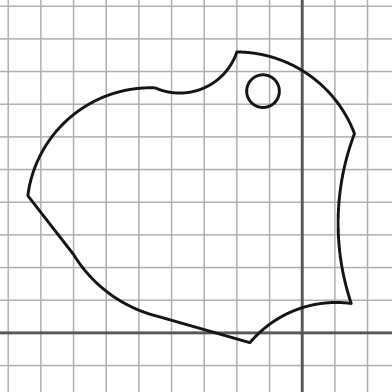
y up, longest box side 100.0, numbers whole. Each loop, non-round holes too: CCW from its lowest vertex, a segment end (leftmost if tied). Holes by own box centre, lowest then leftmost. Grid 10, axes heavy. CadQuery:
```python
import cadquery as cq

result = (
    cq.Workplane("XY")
    .moveTo(-16.0, -3.0)
    .threePointArc((-2.0, 7.0), (15.0, 9.0))
    .threePointArc((11.0, 35.0), (16.0, 61.0))
    .threePointArc((2.0, 79.0), (-20.0, 86.0))
    .threePointArc((-30.0, 75.0), (-45.0, 75.0))
    .threePointArc((-71.0, 66.0), (-84.0, 42.0))
    .lineTo(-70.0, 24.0)
    .threePointArc((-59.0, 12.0), (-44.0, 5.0))
    .close()
    .moveTo(-12.0, 74.0)
    .circle(5.0)
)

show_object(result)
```